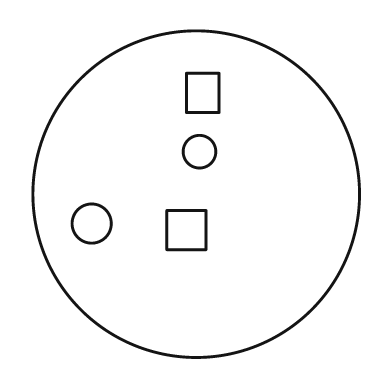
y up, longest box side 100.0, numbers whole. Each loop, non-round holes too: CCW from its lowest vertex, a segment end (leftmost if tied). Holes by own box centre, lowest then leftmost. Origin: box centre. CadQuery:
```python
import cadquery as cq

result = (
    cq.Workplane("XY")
    .moveTo(0.0, 0.0)
    .circle(50.0)
    .moveTo(-9.0, -17.0)
    .lineTo(3.0, -17.0)
    .lineTo(3.0, -5.0)
    .lineTo(-9.0, -5.0)
    .close()
    .moveTo(-32.0, -9.0)
    .circle(6.0)
    .moveTo(1.0, 13.0)
    .circle(5.0)
    .moveTo(-3.0, 25.0)
    .lineTo(7.0, 25.0)
    .lineTo(7.0, 37.0)
    .lineTo(-3.0, 37.0)
    .close()
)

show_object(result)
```